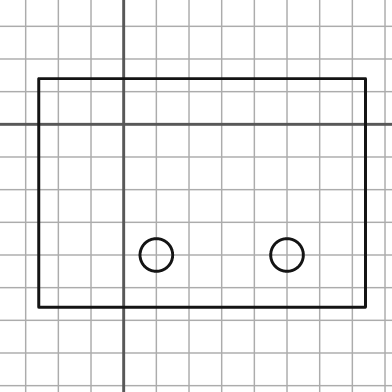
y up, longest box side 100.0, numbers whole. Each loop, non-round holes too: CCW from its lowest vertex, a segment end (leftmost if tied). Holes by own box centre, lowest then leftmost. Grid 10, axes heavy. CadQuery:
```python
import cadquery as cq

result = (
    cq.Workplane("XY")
    .moveTo(-26.0, -56.0)
    .lineTo(74.0, -56.0)
    .lineTo(74.0, 14.0)
    .lineTo(-26.0, 14.0)
    .close()
    .moveTo(10.0, -40.0)
    .circle(5.0)
    .moveTo(50.0, -40.0)
    .circle(5.0)
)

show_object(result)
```